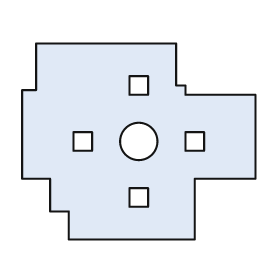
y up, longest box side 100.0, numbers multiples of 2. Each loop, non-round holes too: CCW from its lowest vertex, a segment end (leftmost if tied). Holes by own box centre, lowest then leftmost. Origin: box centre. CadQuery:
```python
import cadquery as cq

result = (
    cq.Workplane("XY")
    .moveTo(-30.0, -42.0)
    .lineTo(24.0, -42.0)
    .lineTo(24.0, -16.0)
    .lineTo(50.0, -16.0)
    .lineTo(50.0, 20.0)
    .lineTo(20.0, 20.0)
    .lineTo(20.0, 24.0)
    .lineTo(16.0, 24.0)
    .lineTo(16.0, 42.0)
    .lineTo(-44.0, 42.0)
    .lineTo(-44.0, 22.0)
    .lineTo(-50.0, 22.0)
    .lineTo(-50.0, -16.0)
    .lineTo(-38.0, -16.0)
    .lineTo(-38.0, -30.0)
    .lineTo(-30.0, -30.0)
    .close()
    .moveTo(-4.0, -28.0)
    .lineTo(4.0, -28.0)
    .lineTo(4.0, -20.0)
    .lineTo(-4.0, -20.0)
    .close()
    .moveTo(-28.0, -4.0)
    .lineTo(-20.0, -4.0)
    .lineTo(-20.0, 4.0)
    .lineTo(-28.0, 4.0)
    .close()
    .moveTo(0.0, 0.0)
    .circle(8.0)
    .moveTo(20.0, -4.0)
    .lineTo(28.0, -4.0)
    .lineTo(28.0, 4.0)
    .lineTo(20.0, 4.0)
    .close()
    .moveTo(-4.0, 20.0)
    .lineTo(4.0, 20.0)
    .lineTo(4.0, 28.0)
    .lineTo(-4.0, 28.0)
    .close()
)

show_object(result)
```